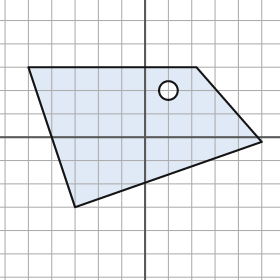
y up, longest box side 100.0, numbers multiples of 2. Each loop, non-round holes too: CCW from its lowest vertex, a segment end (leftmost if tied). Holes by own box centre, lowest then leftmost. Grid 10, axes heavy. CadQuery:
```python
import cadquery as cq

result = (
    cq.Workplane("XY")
    .moveTo(-30.0, -30.0)
    .lineTo(50.0, -2.0)
    .lineTo(22.0, 30.0)
    .lineTo(-50.0, 30.0)
    .close()
    .moveTo(10.0, 20.0)
    .circle(4.0)
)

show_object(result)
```